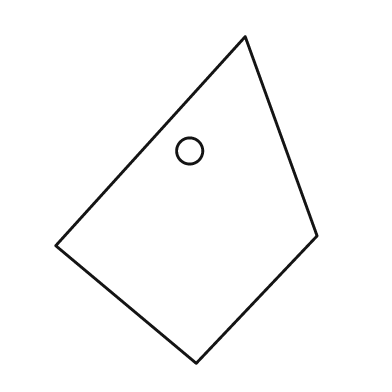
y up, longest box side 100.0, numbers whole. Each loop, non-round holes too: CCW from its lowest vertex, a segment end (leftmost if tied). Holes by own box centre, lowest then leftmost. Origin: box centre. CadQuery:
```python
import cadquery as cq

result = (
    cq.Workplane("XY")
    .moveTo(3.0, -50.0)
    .lineTo(40.0, -11.0)
    .lineTo(18.0, 50.0)
    .lineTo(-40.0, -14.0)
    .close()
    .moveTo(1.0, 15.0)
    .circle(4.0)
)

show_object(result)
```